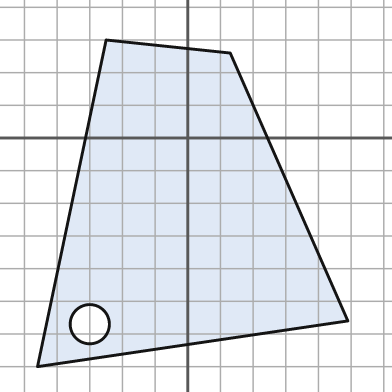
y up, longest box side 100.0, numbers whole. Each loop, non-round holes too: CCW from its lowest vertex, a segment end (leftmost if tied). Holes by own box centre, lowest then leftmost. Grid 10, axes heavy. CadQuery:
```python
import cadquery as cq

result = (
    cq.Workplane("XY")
    .moveTo(-46.0, -70.0)
    .lineTo(49.0, -56.0)
    .lineTo(13.0, 26.0)
    .lineTo(-25.0, 30.0)
    .close()
    .moveTo(-30.0, -57.0)
    .circle(6.0)
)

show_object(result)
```